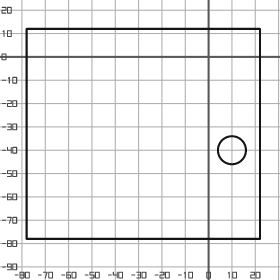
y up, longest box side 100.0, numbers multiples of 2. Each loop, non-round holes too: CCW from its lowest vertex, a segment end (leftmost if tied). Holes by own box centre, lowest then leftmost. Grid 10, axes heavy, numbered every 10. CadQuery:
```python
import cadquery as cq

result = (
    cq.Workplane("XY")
    .moveTo(-78.0, -78.0)
    .lineTo(22.0, -78.0)
    .lineTo(22.0, 12.0)
    .lineTo(-78.0, 12.0)
    .close()
    .moveTo(10.0, -40.0)
    .circle(6.0)
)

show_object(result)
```